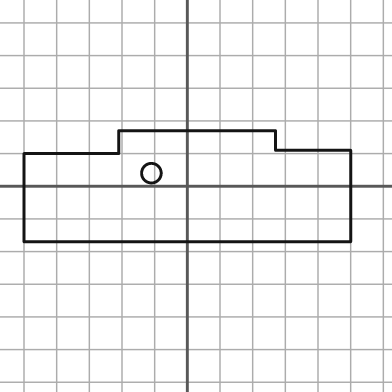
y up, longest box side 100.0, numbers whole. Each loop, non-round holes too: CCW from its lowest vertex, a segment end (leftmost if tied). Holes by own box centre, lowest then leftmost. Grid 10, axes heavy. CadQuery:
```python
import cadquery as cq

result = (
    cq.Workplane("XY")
    .moveTo(-50.0, -17.0)
    .lineTo(50.0, -17.0)
    .lineTo(50.0, 11.0)
    .lineTo(27.0, 11.0)
    .lineTo(27.0, 17.0)
    .lineTo(-21.0, 17.0)
    .lineTo(-21.0, 10.0)
    .lineTo(-50.0, 10.0)
    .close()
    .moveTo(-11.0, 4.0)
    .circle(3.0)
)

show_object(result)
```